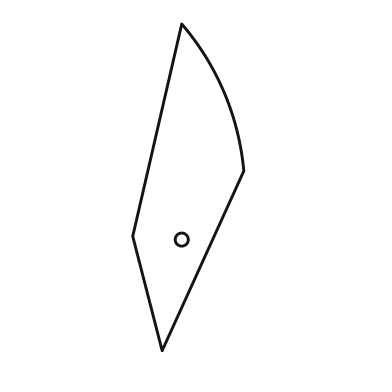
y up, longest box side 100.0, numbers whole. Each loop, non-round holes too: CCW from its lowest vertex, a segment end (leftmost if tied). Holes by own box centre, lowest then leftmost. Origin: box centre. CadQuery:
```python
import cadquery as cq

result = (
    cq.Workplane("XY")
    .moveTo(-8.0, -50.0)
    .lineTo(17.0, 5.0)
    .threePointArc((11.0, 29.0), (-2.0, 50.0))
    .lineTo(-17.0, -15.0)
    .close()
    .moveTo(-2.0, -16.0)
    .circle(2.0)
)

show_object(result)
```